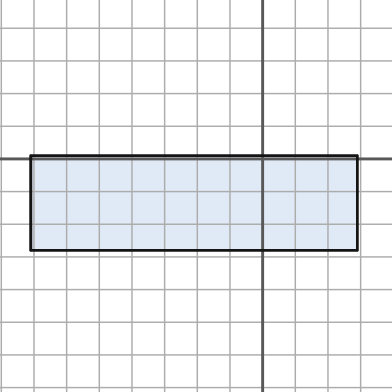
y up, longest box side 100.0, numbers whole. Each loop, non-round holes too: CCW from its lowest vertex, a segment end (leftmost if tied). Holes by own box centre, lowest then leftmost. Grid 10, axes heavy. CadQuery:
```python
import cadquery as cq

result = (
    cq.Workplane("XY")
    .moveTo(-71.0, -28.0)
    .lineTo(29.0, -28.0)
    .lineTo(29.0, 1.0)
    .lineTo(-71.0, 1.0)
    .close()
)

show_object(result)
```